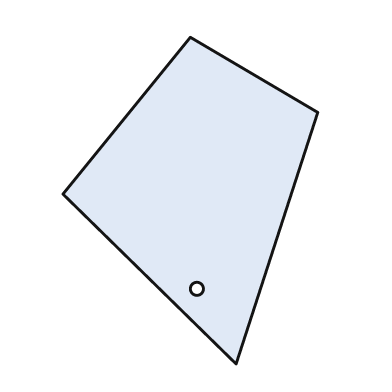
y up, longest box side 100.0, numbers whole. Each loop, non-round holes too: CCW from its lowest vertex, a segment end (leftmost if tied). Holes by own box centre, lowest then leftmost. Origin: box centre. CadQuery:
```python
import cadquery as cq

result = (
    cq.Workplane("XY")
    .moveTo(14.0, -50.0)
    .lineTo(39.0, 27.0)
    .lineTo(0.0, 50.0)
    .lineTo(-39.0, 2.0)
    .close()
    .moveTo(2.0, -27.0)
    .circle(2.0)
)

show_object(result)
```